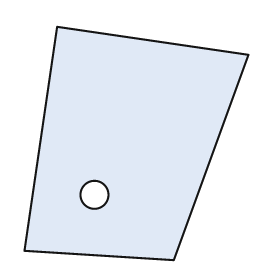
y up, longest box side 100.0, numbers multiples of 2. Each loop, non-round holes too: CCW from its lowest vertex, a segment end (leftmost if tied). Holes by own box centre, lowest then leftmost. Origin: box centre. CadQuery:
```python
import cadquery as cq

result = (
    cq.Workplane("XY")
    .moveTo(16.0, -50.0)
    .lineTo(48.0, 38.0)
    .lineTo(-34.0, 50.0)
    .lineTo(-48.0, -46.0)
    .close()
    .moveTo(-18.0, -22.0)
    .circle(6.0)
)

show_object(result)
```